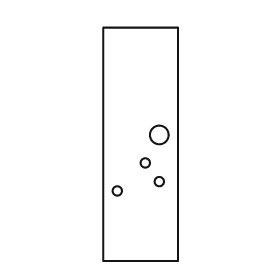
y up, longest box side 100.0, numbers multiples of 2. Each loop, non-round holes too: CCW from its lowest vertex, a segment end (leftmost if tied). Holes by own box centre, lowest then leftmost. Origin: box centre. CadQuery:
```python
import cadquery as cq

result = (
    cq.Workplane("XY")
    .moveTo(-16.0, -50.0)
    .lineTo(16.0, -50.0)
    .lineTo(16.0, 50.0)
    .lineTo(-16.0, 50.0)
    .close()
    .moveTo(-10.0, -20.0)
    .circle(2.0)
    .moveTo(8.0, -16.0)
    .circle(2.0)
    .moveTo(2.0, -8.0)
    .circle(2.0)
    .moveTo(8.0, 4.0)
    .circle(4.0)
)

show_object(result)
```